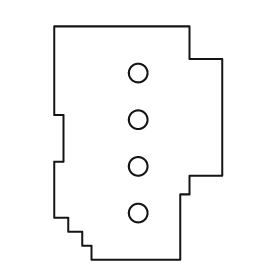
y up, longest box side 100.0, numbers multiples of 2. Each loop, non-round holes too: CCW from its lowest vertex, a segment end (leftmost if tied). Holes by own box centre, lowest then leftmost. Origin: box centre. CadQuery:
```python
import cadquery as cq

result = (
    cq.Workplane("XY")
    .moveTo(-20.0, -50.0)
    .lineTo(18.0, -50.0)
    .lineTo(18.0, -22.0)
    .lineTo(22.0, -22.0)
    .lineTo(22.0, -14.0)
    .lineTo(36.0, -14.0)
    .lineTo(36.0, 36.0)
    .lineTo(22.0, 36.0)
    .lineTo(22.0, 50.0)
    .lineTo(-36.0, 50.0)
    .lineTo(-36.0, 12.0)
    .lineTo(-32.0, 12.0)
    .lineTo(-32.0, -8.0)
    .lineTo(-36.0, -8.0)
    .lineTo(-36.0, -32.0)
    .lineTo(-30.0, -32.0)
    .lineTo(-30.0, -38.0)
    .lineTo(-24.0, -38.0)
    .lineTo(-24.0, -44.0)
    .lineTo(-20.0, -44.0)
    .close()
    .moveTo(0.0, -30.0)
    .circle(4.0)
    .moveTo(0.0, -10.0)
    .circle(4.0)
    .moveTo(0.0, 10.0)
    .circle(4.0)
    .moveTo(0.0, 30.0)
    .circle(4.0)
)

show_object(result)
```